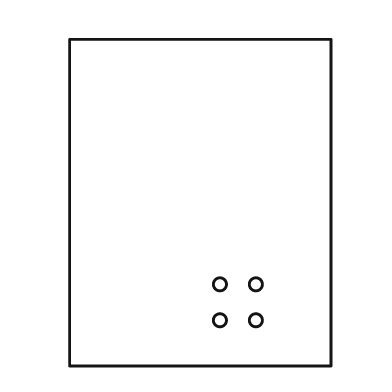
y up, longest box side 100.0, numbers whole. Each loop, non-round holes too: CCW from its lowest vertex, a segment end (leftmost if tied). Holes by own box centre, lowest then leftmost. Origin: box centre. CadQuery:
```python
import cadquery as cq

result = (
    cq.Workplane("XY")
    .moveTo(-40.0, -50.0)
    .lineTo(40.0, -50.0)
    .lineTo(40.0, 50.0)
    .lineTo(-40.0, 50.0)
    .close()
    .moveTo(6.0, -36.0)
    .circle(2.0)
    .moveTo(17.0, -36.0)
    .circle(2.0)
    .moveTo(6.0, -25.0)
    .circle(2.0)
    .moveTo(17.0, -25.0)
    .circle(2.0)
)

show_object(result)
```